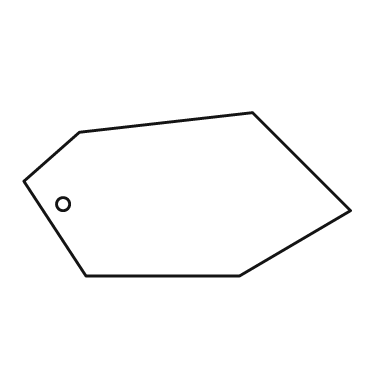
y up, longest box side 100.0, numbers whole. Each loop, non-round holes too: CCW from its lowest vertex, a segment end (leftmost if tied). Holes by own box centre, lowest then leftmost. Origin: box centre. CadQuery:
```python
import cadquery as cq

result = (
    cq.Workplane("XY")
    .moveTo(-31.0, -25.0)
    .lineTo(16.0, -25.0)
    .lineTo(50.0, -5.0)
    .lineTo(20.0, 25.0)
    .lineTo(-33.0, 19.0)
    .lineTo(-50.0, 4.0)
    .close()
    .moveTo(-38.0, -3.0)
    .circle(2.0)
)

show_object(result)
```